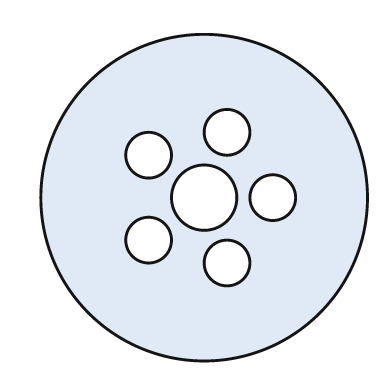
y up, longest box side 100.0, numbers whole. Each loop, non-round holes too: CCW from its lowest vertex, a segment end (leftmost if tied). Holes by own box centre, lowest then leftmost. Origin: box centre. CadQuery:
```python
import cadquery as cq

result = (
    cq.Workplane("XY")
    .moveTo(0.0, 0.0)
    .circle(50.0)
    .moveTo(7.0, -20.0)
    .circle(7.0)
    .moveTo(-17.0, -13.0)
    .circle(7.0)
    .moveTo(0.0, 0.0)
    .circle(10.0)
    .moveTo(21.0, 0.0)
    .circle(7.0)
    .moveTo(-17.0, 13.0)
    .circle(7.0)
    .moveTo(7.0, 20.0)
    .circle(7.0)
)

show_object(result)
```